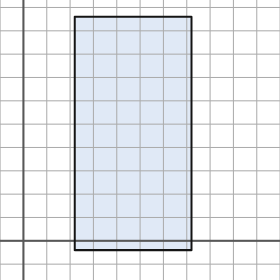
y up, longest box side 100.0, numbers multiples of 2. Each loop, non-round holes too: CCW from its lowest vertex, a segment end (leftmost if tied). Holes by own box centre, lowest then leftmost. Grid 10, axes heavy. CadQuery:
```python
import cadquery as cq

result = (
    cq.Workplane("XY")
    .moveTo(22.0, -4.0)
    .lineTo(72.0, -4.0)
    .lineTo(72.0, 96.0)
    .lineTo(22.0, 96.0)
    .close()
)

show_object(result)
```